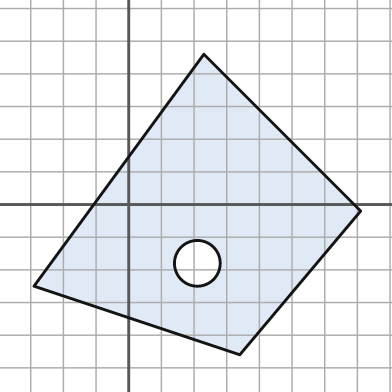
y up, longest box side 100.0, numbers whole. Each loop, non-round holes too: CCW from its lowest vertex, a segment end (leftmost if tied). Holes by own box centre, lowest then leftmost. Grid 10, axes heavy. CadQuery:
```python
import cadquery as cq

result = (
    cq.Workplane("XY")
    .moveTo(34.0, -46.0)
    .lineTo(71.0, -2.0)
    .lineTo(23.0, 46.0)
    .lineTo(-29.0, -25.0)
    .close()
    .moveTo(21.0, -18.0)
    .circle(7.0)
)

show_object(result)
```